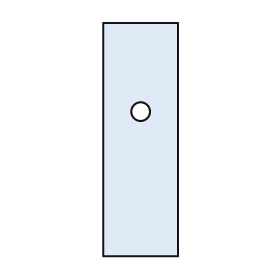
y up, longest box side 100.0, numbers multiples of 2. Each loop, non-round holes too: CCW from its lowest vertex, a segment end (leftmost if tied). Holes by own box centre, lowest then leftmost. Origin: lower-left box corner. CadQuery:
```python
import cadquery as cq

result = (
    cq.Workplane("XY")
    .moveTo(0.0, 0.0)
    .lineTo(32.0, 0.0)
    .lineTo(32.0, 100.0)
    .lineTo(0.0, 100.0)
    .close()
    .moveTo(16.0, 62.0)
    .circle(4.0)
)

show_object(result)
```